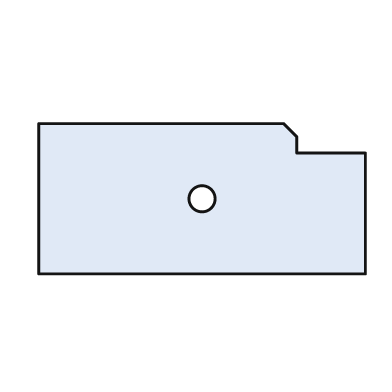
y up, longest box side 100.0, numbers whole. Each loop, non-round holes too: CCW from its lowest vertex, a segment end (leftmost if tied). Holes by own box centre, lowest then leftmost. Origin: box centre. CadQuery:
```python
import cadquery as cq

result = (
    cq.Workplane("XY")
    .moveTo(-50.0, -23.0)
    .lineTo(50.0, -23.0)
    .lineTo(50.0, 14.0)
    .lineTo(29.0, 14.0)
    .lineTo(29.0, 19.0)
    .lineTo(25.0, 23.0)
    .lineTo(-50.0, 23.0)
    .close()
    .moveTo(0.0, 0.0)
    .circle(4.0)
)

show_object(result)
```